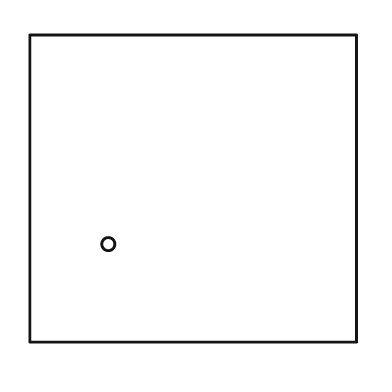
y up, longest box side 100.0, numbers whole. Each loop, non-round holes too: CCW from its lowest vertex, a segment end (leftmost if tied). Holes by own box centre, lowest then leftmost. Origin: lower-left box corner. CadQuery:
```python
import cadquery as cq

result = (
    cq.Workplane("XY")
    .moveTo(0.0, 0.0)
    .lineTo(100.0, 0.0)
    .lineTo(100.0, 94.0)
    .lineTo(0.0, 94.0)
    .close()
    .moveTo(24.0, 30.0)
    .circle(2.0)
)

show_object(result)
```